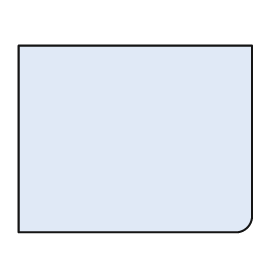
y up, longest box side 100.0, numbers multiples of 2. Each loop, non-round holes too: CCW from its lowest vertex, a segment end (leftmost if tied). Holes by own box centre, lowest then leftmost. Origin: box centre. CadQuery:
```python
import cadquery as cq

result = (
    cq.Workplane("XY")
    .moveTo(-50.0, -40.0)
    .lineTo(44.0, -40.0)
    .threePointArc((48.0, -38.0), (50.0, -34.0))
    .lineTo(50.0, 40.0)
    .lineTo(-50.0, 40.0)
    .close()
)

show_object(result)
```